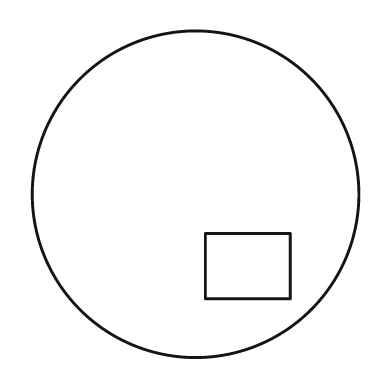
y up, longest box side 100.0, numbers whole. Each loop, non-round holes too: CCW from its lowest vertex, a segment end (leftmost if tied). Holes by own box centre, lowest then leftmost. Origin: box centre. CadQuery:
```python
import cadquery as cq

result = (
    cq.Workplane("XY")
    .moveTo(0.0, 0.0)
    .circle(50.0)
    .moveTo(3.0, -32.0)
    .lineTo(29.0, -32.0)
    .lineTo(29.0, -12.0)
    .lineTo(3.0, -12.0)
    .close()
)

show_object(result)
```